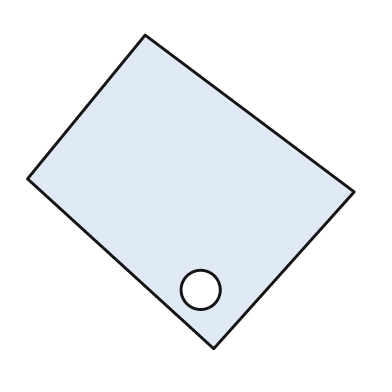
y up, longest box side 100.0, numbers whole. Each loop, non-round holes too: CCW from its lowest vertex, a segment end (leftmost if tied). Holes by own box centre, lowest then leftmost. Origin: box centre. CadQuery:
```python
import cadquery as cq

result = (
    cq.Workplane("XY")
    .moveTo(7.0, -48.0)
    .lineTo(50.0, 0.0)
    .lineTo(-14.0, 48.0)
    .lineTo(-50.0, 4.0)
    .close()
    .moveTo(3.0, -30.0)
    .circle(6.0)
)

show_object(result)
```